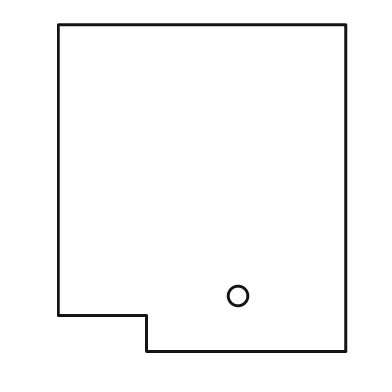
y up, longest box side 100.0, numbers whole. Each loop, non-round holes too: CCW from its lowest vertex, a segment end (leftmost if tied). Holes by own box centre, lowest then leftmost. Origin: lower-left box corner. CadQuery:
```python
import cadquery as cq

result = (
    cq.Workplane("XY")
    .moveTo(27.0, 0.0)
    .lineTo(88.0, 0.0)
    .lineTo(88.0, 100.0)
    .lineTo(0.0, 100.0)
    .lineTo(0.0, 11.0)
    .lineTo(27.0, 11.0)
    .close()
    .moveTo(55.0, 17.0)
    .circle(3.0)
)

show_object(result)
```